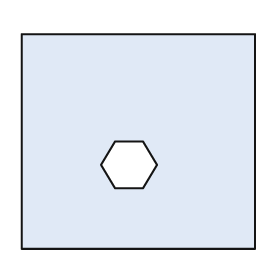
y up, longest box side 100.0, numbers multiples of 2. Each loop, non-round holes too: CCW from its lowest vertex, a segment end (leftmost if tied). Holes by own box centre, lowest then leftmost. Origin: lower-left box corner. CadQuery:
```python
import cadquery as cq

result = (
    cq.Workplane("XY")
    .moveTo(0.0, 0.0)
    .lineTo(100.0, 0.0)
    .lineTo(100.0, 92.0)
    .lineTo(0.0, 92.0)
    .close()
    .moveTo(40.0, 26.0)
    .lineTo(52.0, 26.0)
    .lineTo(58.0, 36.0)
    .lineTo(52.0, 46.0)
    .lineTo(40.0, 46.0)
    .lineTo(34.0, 36.0)
    .close()
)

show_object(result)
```